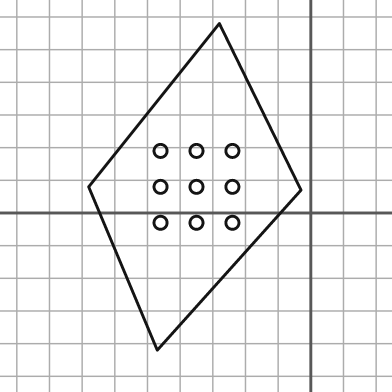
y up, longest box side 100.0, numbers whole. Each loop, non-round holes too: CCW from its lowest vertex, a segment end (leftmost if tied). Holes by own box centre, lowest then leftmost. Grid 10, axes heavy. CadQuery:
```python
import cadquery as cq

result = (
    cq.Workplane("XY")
    .moveTo(-47.0, -42.0)
    .lineTo(-3.0, 7.0)
    .lineTo(-28.0, 58.0)
    .lineTo(-68.0, 8.0)
    .close()
    .moveTo(-46.0, -3.0)
    .circle(2.0)
    .moveTo(-35.0, -3.0)
    .circle(2.0)
    .moveTo(-24.0, -3.0)
    .circle(2.0)
    .moveTo(-46.0, 8.0)
    .circle(2.0)
    .moveTo(-35.0, 8.0)
    .circle(2.0)
    .moveTo(-24.0, 8.0)
    .circle(2.0)
    .moveTo(-46.0, 19.0)
    .circle(2.0)
    .moveTo(-35.0, 19.0)
    .circle(2.0)
    .moveTo(-24.0, 19.0)
    .circle(2.0)
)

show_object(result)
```